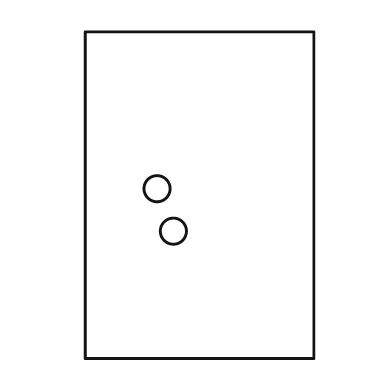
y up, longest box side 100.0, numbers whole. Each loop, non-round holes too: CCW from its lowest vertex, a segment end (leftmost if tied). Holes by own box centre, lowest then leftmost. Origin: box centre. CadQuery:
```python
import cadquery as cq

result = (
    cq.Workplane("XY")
    .moveTo(-35.0, -50.0)
    .lineTo(35.0, -50.0)
    .lineTo(35.0, 50.0)
    .lineTo(-35.0, 50.0)
    .close()
    .moveTo(-8.0, -11.0)
    .circle(4.0)
    .moveTo(-13.0, 2.0)
    .circle(4.0)
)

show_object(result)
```